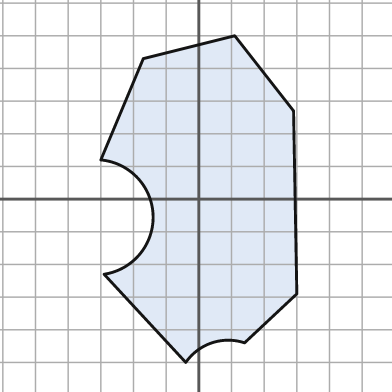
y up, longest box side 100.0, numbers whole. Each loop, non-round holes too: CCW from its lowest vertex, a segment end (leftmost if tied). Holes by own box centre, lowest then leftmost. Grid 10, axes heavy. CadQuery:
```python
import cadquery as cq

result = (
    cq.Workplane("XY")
    .moveTo(-4.0, -50.0)
    .threePointArc((4.0, -44.0), (14.0, -44.0))
    .lineTo(30.0, -29.0)
    .lineTo(29.0, 27.0)
    .lineTo(11.0, 50.0)
    .lineTo(-17.0, 43.0)
    .lineTo(-30.0, 12.0)
    .threePointArc((-14.0, -5.0), (-29.0, -23.0))
    .close()
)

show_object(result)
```